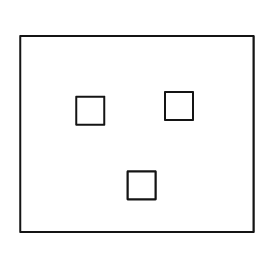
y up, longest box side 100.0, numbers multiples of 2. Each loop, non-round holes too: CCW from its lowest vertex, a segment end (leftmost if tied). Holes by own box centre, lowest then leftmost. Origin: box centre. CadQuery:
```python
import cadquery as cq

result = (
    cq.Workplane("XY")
    .moveTo(-50.0, -42.0)
    .lineTo(50.0, -42.0)
    .lineTo(50.0, 42.0)
    .lineTo(-50.0, 42.0)
    .close()
    .moveTo(-4.0, -28.0)
    .lineTo(8.0, -28.0)
    .lineTo(8.0, -16.0)
    .lineTo(-4.0, -16.0)
    .close()
    .moveTo(-26.0, 4.0)
    .lineTo(-14.0, 4.0)
    .lineTo(-14.0, 16.0)
    .lineTo(-26.0, 16.0)
    .close()
    .moveTo(12.0, 6.0)
    .lineTo(24.0, 6.0)
    .lineTo(24.0, 18.0)
    .lineTo(12.0, 18.0)
    .close()
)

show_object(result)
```